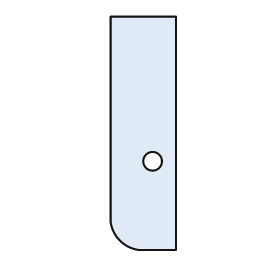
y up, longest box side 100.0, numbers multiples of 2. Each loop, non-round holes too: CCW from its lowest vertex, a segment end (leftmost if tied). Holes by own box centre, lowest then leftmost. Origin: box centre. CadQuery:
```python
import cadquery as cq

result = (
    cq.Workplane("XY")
    .moveTo(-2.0, -50.0)
    .lineTo(14.0, -50.0)
    .lineTo(14.0, 50.0)
    .lineTo(-14.0, 50.0)
    .lineTo(-14.0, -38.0)
    .threePointArc((-10.0, -46.0), (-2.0, -50.0))
    .close()
    .moveTo(4.0, -12.0)
    .circle(4.0)
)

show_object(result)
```